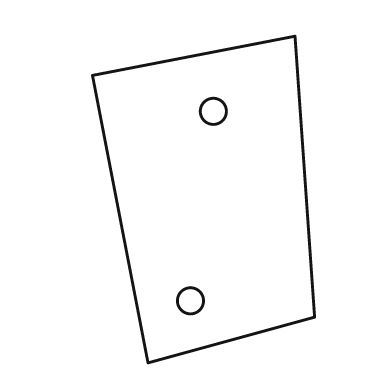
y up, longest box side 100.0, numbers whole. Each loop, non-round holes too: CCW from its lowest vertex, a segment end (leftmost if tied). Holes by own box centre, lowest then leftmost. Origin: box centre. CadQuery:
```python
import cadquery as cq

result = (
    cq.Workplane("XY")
    .moveTo(-17.0, -50.0)
    .lineTo(34.0, -36.0)
    .lineTo(28.0, 50.0)
    .lineTo(-34.0, 38.0)
    .close()
    .moveTo(-4.0, -31.0)
    .circle(4.0)
    .moveTo(3.0, 27.0)
    .circle(4.0)
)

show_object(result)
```